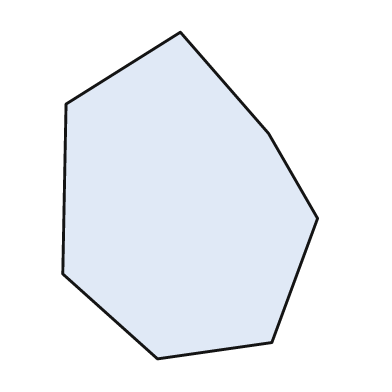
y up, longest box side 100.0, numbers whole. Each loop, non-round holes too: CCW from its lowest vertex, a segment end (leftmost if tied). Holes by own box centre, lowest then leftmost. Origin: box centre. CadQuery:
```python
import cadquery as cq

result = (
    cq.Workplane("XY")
    .moveTo(-10.0, -50.0)
    .lineTo(25.0, -45.0)
    .lineTo(39.0, -7.0)
    .lineTo(24.0, 19.0)
    .lineTo(-3.0, 50.0)
    .lineTo(-38.0, 28.0)
    .lineTo(-39.0, -24.0)
    .close()
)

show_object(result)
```